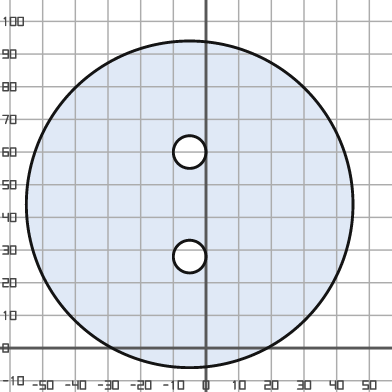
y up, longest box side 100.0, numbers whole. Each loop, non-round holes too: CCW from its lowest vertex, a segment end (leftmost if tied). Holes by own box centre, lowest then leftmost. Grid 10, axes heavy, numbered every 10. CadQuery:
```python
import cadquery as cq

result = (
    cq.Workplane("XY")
    .moveTo(-5.0, 44.0)
    .circle(50.0)
    .moveTo(-5.0, 28.0)
    .circle(5.0)
    .moveTo(-5.0, 60.0)
    .circle(5.0)
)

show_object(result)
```